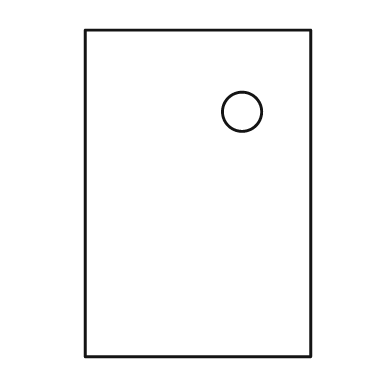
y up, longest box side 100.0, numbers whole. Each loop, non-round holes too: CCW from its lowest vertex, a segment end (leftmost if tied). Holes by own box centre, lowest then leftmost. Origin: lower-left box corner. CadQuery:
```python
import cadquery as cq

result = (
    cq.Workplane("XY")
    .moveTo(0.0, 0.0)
    .lineTo(69.0, 0.0)
    .lineTo(69.0, 100.0)
    .lineTo(0.0, 100.0)
    .close()
    .moveTo(48.0, 75.0)
    .circle(6.0)
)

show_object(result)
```